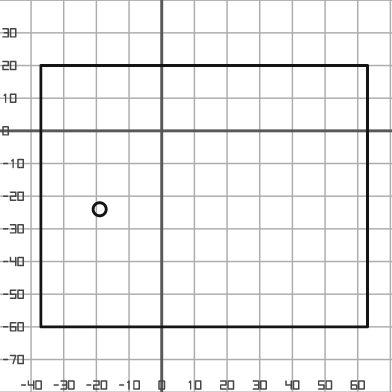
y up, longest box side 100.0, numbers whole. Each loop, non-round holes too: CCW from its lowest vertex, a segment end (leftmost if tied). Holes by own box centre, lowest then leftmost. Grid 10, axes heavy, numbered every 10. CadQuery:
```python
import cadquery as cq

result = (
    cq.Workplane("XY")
    .moveTo(-37.0, -60.0)
    .lineTo(63.0, -60.0)
    .lineTo(63.0, 20.0)
    .lineTo(-37.0, 20.0)
    .close()
    .moveTo(-19.0, -24.0)
    .circle(2.0)
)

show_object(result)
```